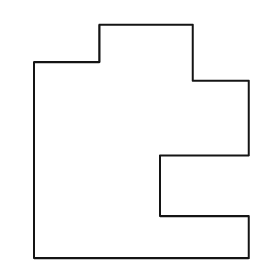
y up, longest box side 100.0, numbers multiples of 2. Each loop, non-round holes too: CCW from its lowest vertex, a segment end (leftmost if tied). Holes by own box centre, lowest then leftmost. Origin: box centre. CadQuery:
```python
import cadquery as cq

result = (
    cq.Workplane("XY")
    .moveTo(-46.0, -50.0)
    .lineTo(46.0, -50.0)
    .lineTo(46.0, -32.0)
    .lineTo(8.0, -32.0)
    .lineTo(8.0, -6.0)
    .lineTo(46.0, -6.0)
    .lineTo(46.0, 26.0)
    .lineTo(22.0, 26.0)
    .lineTo(22.0, 50.0)
    .lineTo(-18.0, 50.0)
    .lineTo(-18.0, 34.0)
    .lineTo(-46.0, 34.0)
    .close()
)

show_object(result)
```